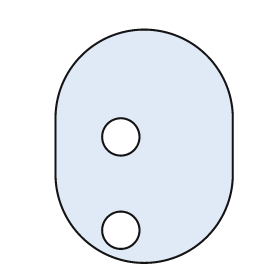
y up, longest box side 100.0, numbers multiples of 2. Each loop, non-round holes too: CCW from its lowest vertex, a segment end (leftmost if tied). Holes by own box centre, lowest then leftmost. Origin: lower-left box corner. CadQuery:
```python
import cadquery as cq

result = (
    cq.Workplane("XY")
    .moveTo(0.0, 38.0)
    .threePointArc((38.0, 0.0), (76.0, 38.0))
    .lineTo(76.0, 62.0)
    .threePointArc((38.0, 100.0), (0.0, 62.0))
    .close()
    .moveTo(28.0, 14.0)
    .circle(8.0)
    .moveTo(28.0, 54.0)
    .circle(8.0)
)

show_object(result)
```